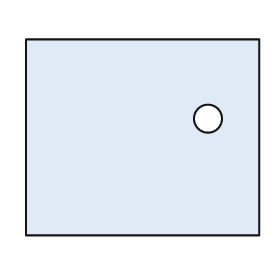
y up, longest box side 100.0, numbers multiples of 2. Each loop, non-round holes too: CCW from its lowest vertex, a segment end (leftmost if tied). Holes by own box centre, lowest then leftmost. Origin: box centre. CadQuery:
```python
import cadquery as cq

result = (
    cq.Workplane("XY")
    .moveTo(-50.0, -42.0)
    .lineTo(50.0, -42.0)
    .lineTo(50.0, 42.0)
    .lineTo(-50.0, 42.0)
    .close()
    .moveTo(28.0, 8.0)
    .circle(6.0)
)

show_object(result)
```